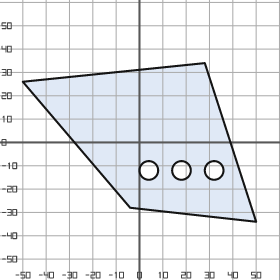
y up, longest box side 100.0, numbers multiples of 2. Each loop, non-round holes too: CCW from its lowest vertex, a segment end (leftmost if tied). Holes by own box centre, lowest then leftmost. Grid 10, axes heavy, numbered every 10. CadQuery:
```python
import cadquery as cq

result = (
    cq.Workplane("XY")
    .moveTo(50.0, -34.0)
    .lineTo(28.0, 34.0)
    .lineTo(-50.0, 26.0)
    .lineTo(-4.0, -28.0)
    .close()
    .moveTo(4.0, -12.0)
    .circle(4.0)
    .moveTo(18.0, -12.0)
    .circle(4.0)
    .moveTo(32.0, -12.0)
    .circle(4.0)
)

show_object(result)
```